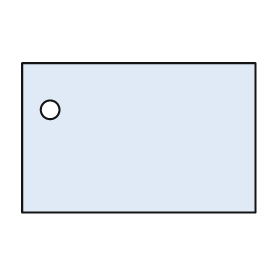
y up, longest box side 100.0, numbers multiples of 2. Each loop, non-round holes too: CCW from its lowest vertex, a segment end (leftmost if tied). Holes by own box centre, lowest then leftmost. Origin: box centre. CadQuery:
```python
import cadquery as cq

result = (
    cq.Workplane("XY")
    .moveTo(-50.0, -32.0)
    .lineTo(50.0, -32.0)
    .lineTo(50.0, 32.0)
    .lineTo(-50.0, 32.0)
    .close()
    .moveTo(-38.0, 12.0)
    .circle(4.0)
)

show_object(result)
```